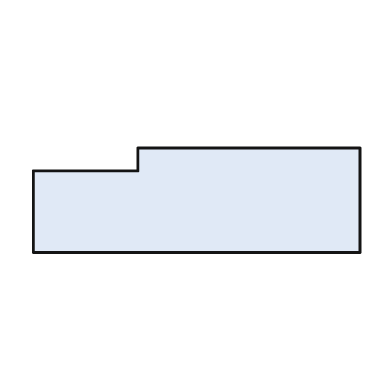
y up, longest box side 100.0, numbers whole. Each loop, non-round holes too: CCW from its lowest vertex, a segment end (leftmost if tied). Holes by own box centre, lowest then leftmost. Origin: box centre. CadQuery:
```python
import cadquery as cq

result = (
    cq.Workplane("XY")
    .moveTo(-50.0, -16.0)
    .lineTo(50.0, -16.0)
    .lineTo(50.0, 16.0)
    .lineTo(-18.0, 16.0)
    .lineTo(-18.0, 9.0)
    .lineTo(-50.0, 9.0)
    .close()
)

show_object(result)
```